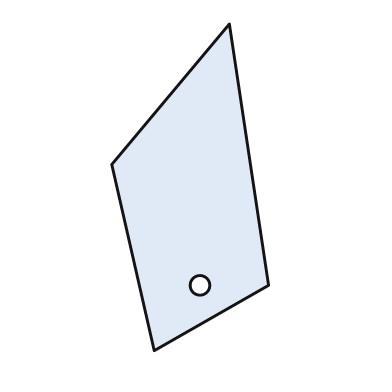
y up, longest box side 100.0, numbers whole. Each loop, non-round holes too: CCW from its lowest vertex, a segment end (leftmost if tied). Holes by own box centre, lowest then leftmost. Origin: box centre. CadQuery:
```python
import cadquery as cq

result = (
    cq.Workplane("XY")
    .moveTo(-11.0, -50.0)
    .lineTo(24.0, -30.0)
    .lineTo(12.0, 50.0)
    .lineTo(-24.0, 7.0)
    .close()
    .moveTo(3.0, -30.0)
    .circle(3.0)
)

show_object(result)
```